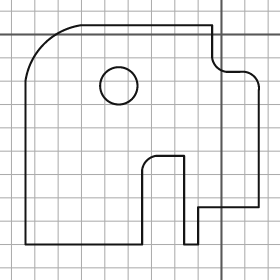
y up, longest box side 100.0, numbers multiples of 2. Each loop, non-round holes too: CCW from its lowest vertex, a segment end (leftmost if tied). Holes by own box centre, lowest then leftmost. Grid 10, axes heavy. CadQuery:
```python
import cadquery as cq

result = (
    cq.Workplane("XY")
    .moveTo(-84.0, -90.0)
    .lineTo(-34.0, -90.0)
    .lineTo(-34.0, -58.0)
    .threePointArc((-32.0, -54.0), (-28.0, -52.0))
    .lineTo(-16.0, -52.0)
    .lineTo(-16.0, -90.0)
    .lineTo(-10.0, -90.0)
    .lineTo(-10.0, -74.0)
    .lineTo(16.0, -74.0)
    .lineTo(16.0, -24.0)
    .threePointArc((14.0, -18.0), (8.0, -16.0))
    .lineTo(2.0, -16.0)
    .threePointArc((-2.0, -14.0), (-4.0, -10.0))
    .lineTo(-4.0, 4.0)
    .lineTo(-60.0, 4.0)
    .threePointArc((-76.0, -4.0), (-84.0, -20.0))
    .close()
    .moveTo(-44.0, -22.0)
    .circle(8.0)
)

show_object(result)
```